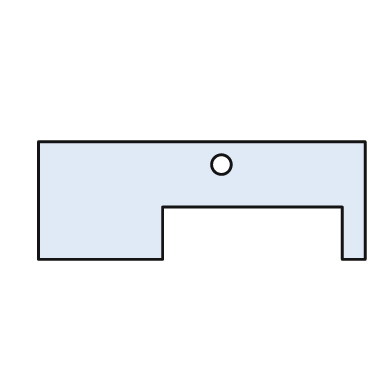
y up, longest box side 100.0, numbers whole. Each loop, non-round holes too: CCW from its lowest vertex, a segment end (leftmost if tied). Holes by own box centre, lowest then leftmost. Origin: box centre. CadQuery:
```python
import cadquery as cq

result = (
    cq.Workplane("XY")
    .moveTo(-50.0, -18.0)
    .lineTo(-12.0, -18.0)
    .lineTo(-12.0, -2.0)
    .lineTo(43.0, -2.0)
    .lineTo(43.0, -18.0)
    .lineTo(50.0, -18.0)
    .lineTo(50.0, 18.0)
    .lineTo(-50.0, 18.0)
    .close()
    .moveTo(6.0, 11.0)
    .circle(3.0)
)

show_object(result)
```